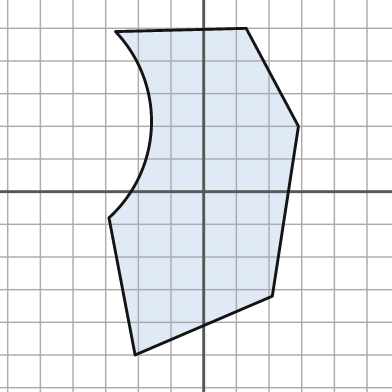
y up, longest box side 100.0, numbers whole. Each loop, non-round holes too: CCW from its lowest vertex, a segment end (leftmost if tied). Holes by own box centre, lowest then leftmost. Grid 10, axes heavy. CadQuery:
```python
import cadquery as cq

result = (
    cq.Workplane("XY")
    .moveTo(-21.0, -50.0)
    .lineTo(21.0, -32.0)
    .lineTo(29.0, 20.0)
    .lineTo(13.0, 50.0)
    .lineTo(-27.0, 49.0)
    .threePointArc((-16.0, 20.0), (-29.0, -8.0))
    .close()
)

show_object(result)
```